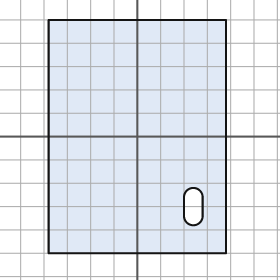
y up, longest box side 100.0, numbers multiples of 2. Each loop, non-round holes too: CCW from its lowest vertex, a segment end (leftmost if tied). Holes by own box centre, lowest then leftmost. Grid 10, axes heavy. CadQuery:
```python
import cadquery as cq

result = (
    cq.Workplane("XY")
    .moveTo(-38.0, -50.0)
    .lineTo(38.0, -50.0)
    .lineTo(38.0, 50.0)
    .lineTo(-38.0, 50.0)
    .close()
    .moveTo(20.0, -34.0)
    .threePointArc((24.0, -38.0), (28.0, -34.0))
    .lineTo(28.0, -26.0)
    .threePointArc((24.0, -22.0), (20.0, -26.0))
    .close()
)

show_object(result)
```